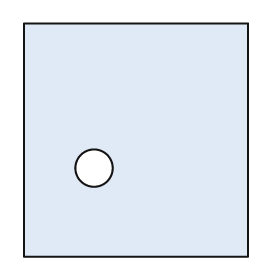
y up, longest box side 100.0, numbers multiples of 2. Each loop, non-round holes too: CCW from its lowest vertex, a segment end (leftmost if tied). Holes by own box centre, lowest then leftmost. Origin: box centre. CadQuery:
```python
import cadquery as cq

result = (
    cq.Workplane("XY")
    .moveTo(-48.0, -50.0)
    .lineTo(48.0, -50.0)
    .lineTo(48.0, 50.0)
    .lineTo(-48.0, 50.0)
    .close()
    .moveTo(-18.0, -12.0)
    .circle(8.0)
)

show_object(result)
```